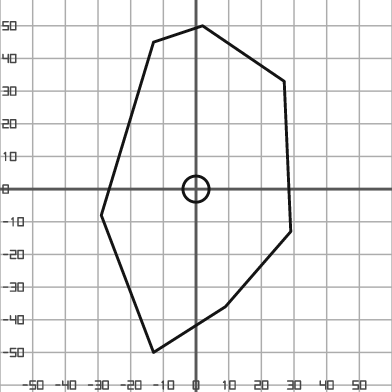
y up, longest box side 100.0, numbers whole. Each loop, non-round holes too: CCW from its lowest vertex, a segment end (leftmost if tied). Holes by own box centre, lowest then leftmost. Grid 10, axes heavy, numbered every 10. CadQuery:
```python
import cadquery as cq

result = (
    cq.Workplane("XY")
    .moveTo(-13.0, -50.0)
    .lineTo(9.0, -36.0)
    .lineTo(29.0, -13.0)
    .lineTo(27.0, 33.0)
    .lineTo(2.0, 50.0)
    .lineTo(-13.0, 45.0)
    .lineTo(-29.0, -8.0)
    .close()
    .moveTo(0.0, 0.0)
    .circle(4.0)
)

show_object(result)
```